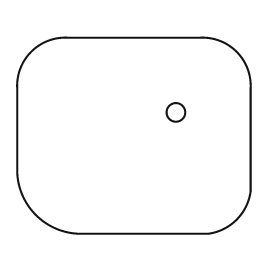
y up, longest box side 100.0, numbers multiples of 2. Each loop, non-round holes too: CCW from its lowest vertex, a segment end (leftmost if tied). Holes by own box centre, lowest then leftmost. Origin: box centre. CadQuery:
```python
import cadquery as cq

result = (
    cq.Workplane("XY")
    .moveTo(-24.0, -42.0)
    .lineTo(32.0, -42.0)
    .threePointArc((44.0, -36.0), (50.0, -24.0))
    .lineTo(50.0, 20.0)
    .threePointArc((44.0, 36.0), (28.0, 42.0))
    .lineTo(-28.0, 42.0)
    .threePointArc((-44.0, 36.0), (-50.0, 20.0))
    .lineTo(-50.0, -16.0)
    .threePointArc((-42.0, -34.0), (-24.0, -42.0))
    .close()
    .moveTo(18.0, 10.0)
    .circle(4.0)
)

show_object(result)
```